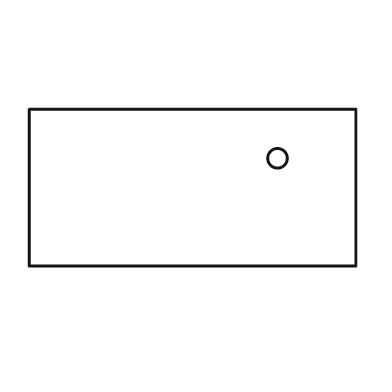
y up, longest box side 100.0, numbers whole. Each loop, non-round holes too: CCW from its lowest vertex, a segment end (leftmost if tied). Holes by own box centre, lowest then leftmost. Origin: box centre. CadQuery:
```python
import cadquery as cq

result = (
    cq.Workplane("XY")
    .moveTo(-50.0, -24.0)
    .lineTo(50.0, -24.0)
    .lineTo(50.0, 24.0)
    .lineTo(-50.0, 24.0)
    .close()
    .moveTo(26.0, 9.0)
    .circle(3.0)
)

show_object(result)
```